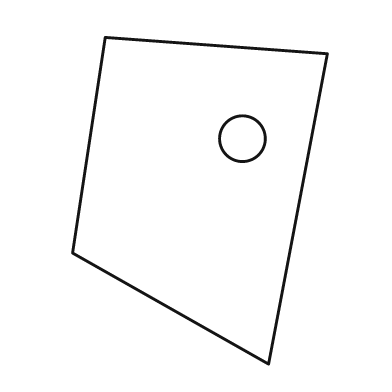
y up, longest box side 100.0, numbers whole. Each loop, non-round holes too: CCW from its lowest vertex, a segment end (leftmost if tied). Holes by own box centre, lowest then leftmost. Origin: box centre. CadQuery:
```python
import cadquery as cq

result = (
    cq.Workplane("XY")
    .moveTo(21.0, -50.0)
    .lineTo(39.0, 45.0)
    .lineTo(-29.0, 50.0)
    .lineTo(-39.0, -16.0)
    .close()
    .moveTo(13.0, 19.0)
    .circle(7.0)
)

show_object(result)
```